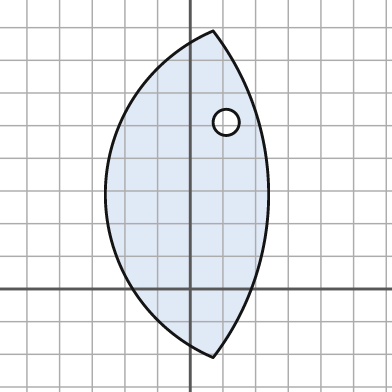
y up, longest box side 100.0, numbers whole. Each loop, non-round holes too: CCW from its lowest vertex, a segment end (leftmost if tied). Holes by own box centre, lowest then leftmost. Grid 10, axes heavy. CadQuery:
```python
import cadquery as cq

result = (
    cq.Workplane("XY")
    .moveTo(7.0, -21.0)
    .threePointArc((24.0, 29.0), (7.0, 79.0))
    .threePointArc((-26.0, 29.0), (7.0, -21.0))
    .close()
    .moveTo(11.0, 51.0)
    .circle(4.0)
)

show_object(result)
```